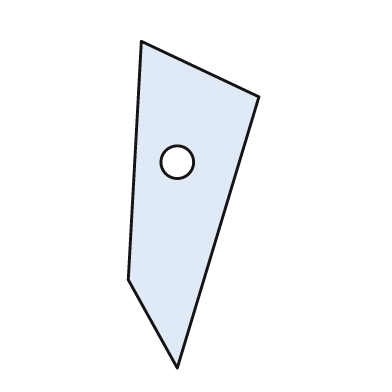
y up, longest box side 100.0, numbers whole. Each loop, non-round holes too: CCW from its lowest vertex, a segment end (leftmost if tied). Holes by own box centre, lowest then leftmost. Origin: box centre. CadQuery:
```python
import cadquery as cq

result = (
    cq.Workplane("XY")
    .moveTo(-5.0, -50.0)
    .lineTo(20.0, 33.0)
    .lineTo(-16.0, 50.0)
    .lineTo(-20.0, -23.0)
    .close()
    .moveTo(-5.0, 13.0)
    .circle(5.0)
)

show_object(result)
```